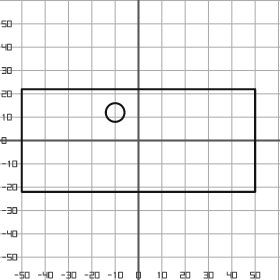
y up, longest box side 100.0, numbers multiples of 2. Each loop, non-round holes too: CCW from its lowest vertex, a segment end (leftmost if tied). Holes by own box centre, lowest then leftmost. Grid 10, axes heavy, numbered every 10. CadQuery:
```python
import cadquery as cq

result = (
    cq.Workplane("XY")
    .moveTo(-50.0, -22.0)
    .lineTo(50.0, -22.0)
    .lineTo(50.0, 22.0)
    .lineTo(-50.0, 22.0)
    .close()
    .moveTo(-10.0, 12.0)
    .circle(4.0)
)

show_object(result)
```